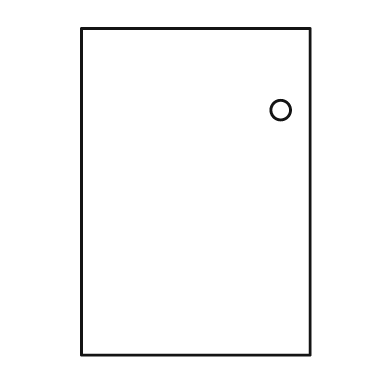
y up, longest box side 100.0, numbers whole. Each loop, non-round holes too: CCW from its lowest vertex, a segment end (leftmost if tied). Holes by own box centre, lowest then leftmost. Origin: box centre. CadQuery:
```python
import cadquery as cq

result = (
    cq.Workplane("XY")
    .moveTo(-35.0, -50.0)
    .lineTo(35.0, -50.0)
    .lineTo(35.0, 50.0)
    .lineTo(-35.0, 50.0)
    .close()
    .moveTo(26.0, 25.0)
    .circle(3.0)
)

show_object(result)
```